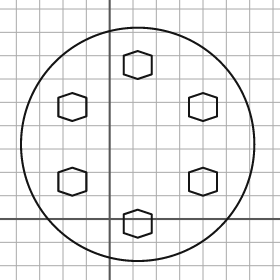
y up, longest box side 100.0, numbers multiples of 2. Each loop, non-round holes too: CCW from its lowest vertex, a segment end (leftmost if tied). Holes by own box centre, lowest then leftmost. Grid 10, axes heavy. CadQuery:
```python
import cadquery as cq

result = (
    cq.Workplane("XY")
    .moveTo(12.0, 32.0)
    .circle(50.0)
    .moveTo(12.0, -8.0)
    .lineTo(18.0, -6.0)
    .lineTo(18.0, 2.0)
    .lineTo(12.0, 4.0)
    .lineTo(6.0, 2.0)
    .lineTo(6.0, -6.0)
    .close()
    .moveTo(-16.0, 10.0)
    .lineTo(-10.0, 12.0)
    .lineTo(-10.0, 20.0)
    .lineTo(-16.0, 22.0)
    .lineTo(-22.0, 20.0)
    .lineTo(-22.0, 12.0)
    .close()
    .moveTo(40.0, 10.0)
    .lineTo(46.0, 12.0)
    .lineTo(46.0, 20.0)
    .lineTo(40.0, 22.0)
    .lineTo(34.0, 20.0)
    .lineTo(34.0, 12.0)
    .close()
    .moveTo(-16.0, 42.0)
    .lineTo(-10.0, 44.0)
    .lineTo(-10.0, 52.0)
    .lineTo(-16.0, 54.0)
    .lineTo(-22.0, 52.0)
    .lineTo(-22.0, 44.0)
    .close()
    .moveTo(40.0, 42.0)
    .lineTo(46.0, 44.0)
    .lineTo(46.0, 52.0)
    .lineTo(40.0, 54.0)
    .lineTo(34.0, 52.0)
    .lineTo(34.0, 44.0)
    .close()
    .moveTo(12.0, 60.0)
    .lineTo(18.0, 62.0)
    .lineTo(18.0, 70.0)
    .lineTo(12.0, 72.0)
    .lineTo(6.0, 70.0)
    .lineTo(6.0, 62.0)
    .close()
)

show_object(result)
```